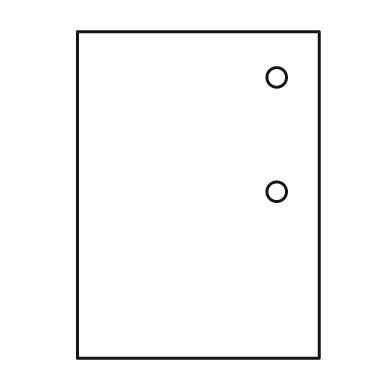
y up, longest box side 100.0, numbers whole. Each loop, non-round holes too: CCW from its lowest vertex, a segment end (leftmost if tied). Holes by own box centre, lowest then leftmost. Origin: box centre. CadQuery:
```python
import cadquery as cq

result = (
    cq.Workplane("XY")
    .moveTo(-37.0, -50.0)
    .lineTo(37.0, -50.0)
    .lineTo(37.0, 50.0)
    .lineTo(-37.0, 50.0)
    .close()
    .moveTo(24.0, 1.0)
    .circle(3.0)
    .moveTo(24.0, 36.0)
    .circle(3.0)
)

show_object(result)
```